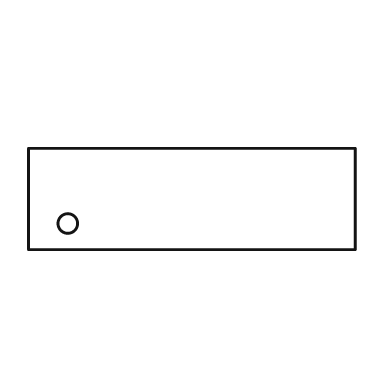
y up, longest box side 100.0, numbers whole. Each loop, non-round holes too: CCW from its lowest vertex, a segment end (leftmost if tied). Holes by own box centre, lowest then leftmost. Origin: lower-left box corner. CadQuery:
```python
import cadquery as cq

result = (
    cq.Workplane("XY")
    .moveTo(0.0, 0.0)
    .lineTo(100.0, 0.0)
    .lineTo(100.0, 31.0)
    .lineTo(0.0, 31.0)
    .close()
    .moveTo(12.0, 8.0)
    .circle(3.0)
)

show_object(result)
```